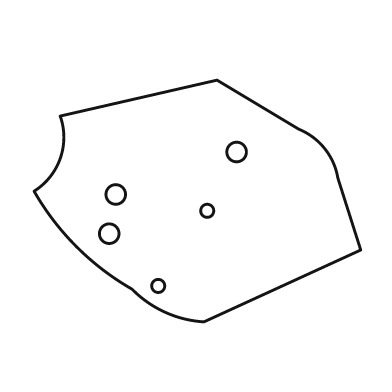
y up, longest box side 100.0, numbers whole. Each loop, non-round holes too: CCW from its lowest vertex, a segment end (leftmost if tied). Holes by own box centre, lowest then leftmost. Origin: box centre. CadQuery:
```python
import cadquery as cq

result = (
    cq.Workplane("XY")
    .moveTo(2.0, -37.0)
    .lineTo(50.0, -15.0)
    .lineTo(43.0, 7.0)
    .threePointArc((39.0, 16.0), (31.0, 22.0))
    .lineTo(6.0, 37.0)
    .lineTo(-42.0, 26.0)
    .threePointArc((-42.0, 13.0), (-50.0, 3.0))
    .threePointArc((-37.0, -14.0), (-20.0, -27.0))
    .threePointArc((-10.0, -34.0), (2.0, -37.0))
    .close()
    .moveTo(-12.0, -26.0)
    .circle(2.0)
    .moveTo(-27.0, -10.0)
    .circle(3.0)
    .moveTo(3.0, -3.0)
    .circle(2.0)
    .moveTo(-25.0, 2.0)
    .circle(3.0)
    .moveTo(12.0, 15.0)
    .circle(3.0)
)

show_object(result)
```